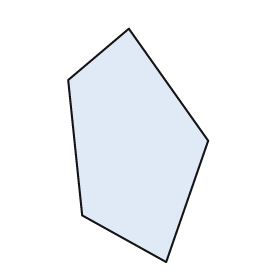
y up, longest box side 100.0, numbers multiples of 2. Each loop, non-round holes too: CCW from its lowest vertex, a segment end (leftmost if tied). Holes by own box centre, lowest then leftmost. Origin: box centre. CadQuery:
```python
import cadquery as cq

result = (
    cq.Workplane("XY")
    .moveTo(12.0, -50.0)
    .lineTo(30.0, 2.0)
    .lineTo(-4.0, 50.0)
    .lineTo(-30.0, 28.0)
    .lineTo(-24.0, -30.0)
    .close()
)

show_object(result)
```